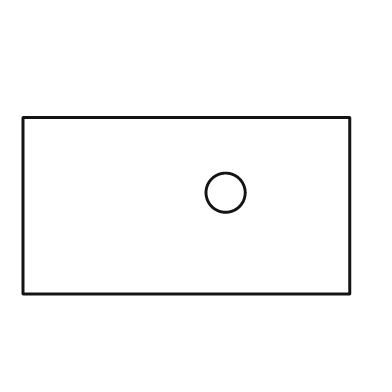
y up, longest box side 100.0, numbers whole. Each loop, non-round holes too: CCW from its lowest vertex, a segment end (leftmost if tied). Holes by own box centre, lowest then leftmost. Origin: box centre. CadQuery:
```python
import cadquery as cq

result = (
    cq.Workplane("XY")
    .moveTo(-50.0, -27.0)
    .lineTo(50.0, -27.0)
    .lineTo(50.0, 27.0)
    .lineTo(-50.0, 27.0)
    .close()
    .moveTo(12.0, 4.0)
    .circle(6.0)
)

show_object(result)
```